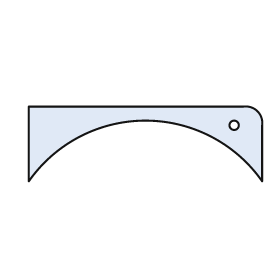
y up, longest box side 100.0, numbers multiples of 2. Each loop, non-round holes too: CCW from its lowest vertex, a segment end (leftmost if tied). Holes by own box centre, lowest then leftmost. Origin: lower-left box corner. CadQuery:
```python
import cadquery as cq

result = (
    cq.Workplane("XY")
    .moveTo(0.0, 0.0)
    .threePointArc((50.0, 26.0), (100.0, 0.0))
    .lineTo(100.0, 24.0)
    .threePointArc((98.0, 30.0), (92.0, 32.0))
    .lineTo(0.0, 32.0)
    .close()
    .moveTo(88.0, 24.0)
    .circle(2.0)
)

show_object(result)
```